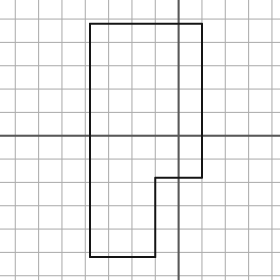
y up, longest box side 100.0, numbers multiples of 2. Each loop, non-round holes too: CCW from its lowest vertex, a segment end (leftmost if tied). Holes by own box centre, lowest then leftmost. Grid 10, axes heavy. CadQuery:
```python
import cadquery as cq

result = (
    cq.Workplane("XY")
    .moveTo(-38.0, -52.0)
    .lineTo(-10.0, -52.0)
    .lineTo(-10.0, -18.0)
    .lineTo(10.0, -18.0)
    .lineTo(10.0, 48.0)
    .lineTo(-38.0, 48.0)
    .close()
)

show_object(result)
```